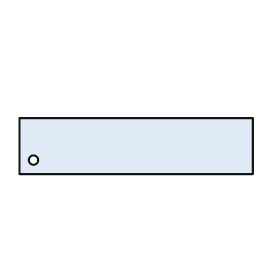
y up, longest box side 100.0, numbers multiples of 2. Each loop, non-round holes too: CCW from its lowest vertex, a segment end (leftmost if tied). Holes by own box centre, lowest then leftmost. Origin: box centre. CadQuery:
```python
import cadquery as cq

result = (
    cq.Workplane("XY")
    .moveTo(-50.0, -12.0)
    .lineTo(50.0, -12.0)
    .lineTo(50.0, 12.0)
    .lineTo(-50.0, 12.0)
    .close()
    .moveTo(-44.0, -6.0)
    .circle(2.0)
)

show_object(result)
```